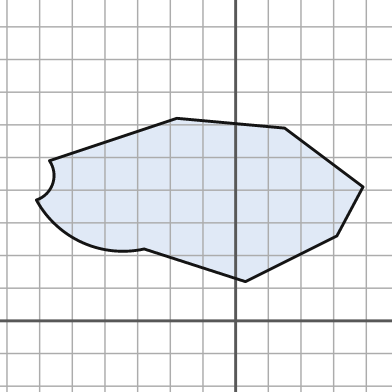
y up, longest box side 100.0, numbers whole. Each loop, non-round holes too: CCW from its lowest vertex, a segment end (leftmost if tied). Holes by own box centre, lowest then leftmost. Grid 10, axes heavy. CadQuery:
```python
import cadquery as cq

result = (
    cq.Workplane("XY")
    .moveTo(3.0, 12.0)
    .lineTo(31.0, 26.0)
    .lineTo(39.0, 41.0)
    .lineTo(15.0, 59.0)
    .lineTo(-18.0, 62.0)
    .lineTo(-57.0, 49.0)
    .threePointArc((-56.0, 42.0), (-61.0, 37.0))
    .threePointArc((-47.0, 24.0), (-28.0, 22.0))
    .close()
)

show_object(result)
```